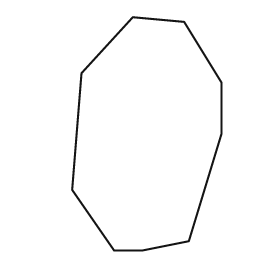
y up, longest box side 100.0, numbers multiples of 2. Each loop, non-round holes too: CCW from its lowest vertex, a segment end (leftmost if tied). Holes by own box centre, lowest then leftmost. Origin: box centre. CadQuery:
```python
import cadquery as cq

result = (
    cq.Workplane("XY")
    .moveTo(-14.0, -50.0)
    .lineTo(-2.0, -50.0)
    .lineTo(18.0, -46.0)
    .lineTo(32.0, 0.0)
    .lineTo(32.0, 22.0)
    .lineTo(16.0, 48.0)
    .lineTo(-6.0, 50.0)
    .lineTo(-28.0, 26.0)
    .lineTo(-32.0, -24.0)
    .close()
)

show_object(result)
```